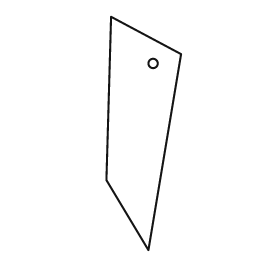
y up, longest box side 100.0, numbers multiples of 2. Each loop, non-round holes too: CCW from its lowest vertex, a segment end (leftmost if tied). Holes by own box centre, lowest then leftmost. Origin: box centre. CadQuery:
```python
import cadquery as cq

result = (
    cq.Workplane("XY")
    .moveTo(2.0, -50.0)
    .lineTo(16.0, 34.0)
    .lineTo(-14.0, 50.0)
    .lineTo(-16.0, -20.0)
    .close()
    .moveTo(4.0, 30.0)
    .circle(2.0)
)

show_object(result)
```